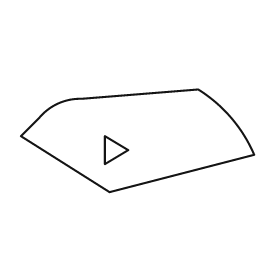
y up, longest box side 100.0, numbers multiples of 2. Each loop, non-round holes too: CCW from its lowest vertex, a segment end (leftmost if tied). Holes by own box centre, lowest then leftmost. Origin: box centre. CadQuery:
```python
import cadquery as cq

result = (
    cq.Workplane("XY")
    .moveTo(-12.0, -22.0)
    .lineTo(50.0, -6.0)
    .threePointArc((40.0, 10.0), (26.0, 22.0))
    .lineTo(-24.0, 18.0)
    .threePointArc((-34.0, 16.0), (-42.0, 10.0))
    .lineTo(-50.0, 2.0)
    .close()
    .moveTo(-14.0, -10.0)
    .lineTo(-4.0, -4.0)
    .lineTo(-14.0, 2.0)
    .close()
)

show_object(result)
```